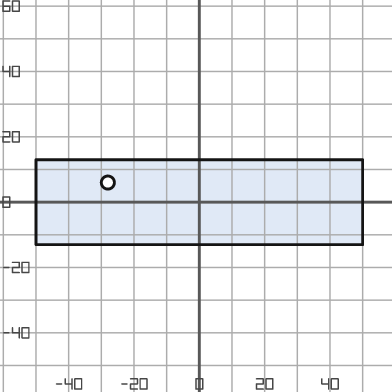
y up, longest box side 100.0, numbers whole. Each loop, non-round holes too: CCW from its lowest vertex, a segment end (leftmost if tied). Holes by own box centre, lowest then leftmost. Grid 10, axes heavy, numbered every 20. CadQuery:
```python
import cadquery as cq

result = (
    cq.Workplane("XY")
    .moveTo(-50.0, -13.0)
    .lineTo(50.0, -13.0)
    .lineTo(50.0, 13.0)
    .lineTo(-50.0, 13.0)
    .close()
    .moveTo(-28.0, 6.0)
    .circle(2.0)
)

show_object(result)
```